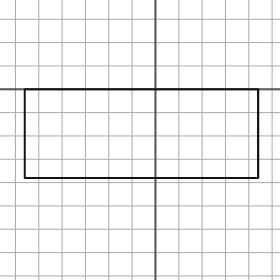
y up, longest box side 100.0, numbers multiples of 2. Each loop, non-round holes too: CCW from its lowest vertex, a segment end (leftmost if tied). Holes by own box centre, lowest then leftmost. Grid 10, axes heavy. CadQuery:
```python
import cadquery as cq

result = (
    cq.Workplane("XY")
    .moveTo(-56.0, -38.0)
    .lineTo(44.0, -38.0)
    .lineTo(44.0, 0.0)
    .lineTo(-56.0, 0.0)
    .close()
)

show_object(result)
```